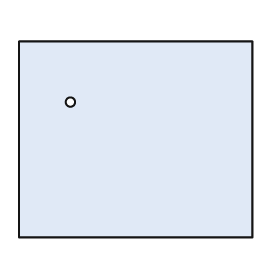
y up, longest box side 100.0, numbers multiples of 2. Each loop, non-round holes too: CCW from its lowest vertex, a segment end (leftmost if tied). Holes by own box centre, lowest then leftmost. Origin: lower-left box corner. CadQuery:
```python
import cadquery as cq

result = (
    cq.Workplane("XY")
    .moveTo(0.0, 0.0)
    .lineTo(100.0, 0.0)
    .lineTo(100.0, 84.0)
    .lineTo(0.0, 84.0)
    .close()
    .moveTo(22.0, 58.0)
    .circle(2.0)
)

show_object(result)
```